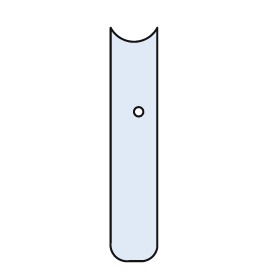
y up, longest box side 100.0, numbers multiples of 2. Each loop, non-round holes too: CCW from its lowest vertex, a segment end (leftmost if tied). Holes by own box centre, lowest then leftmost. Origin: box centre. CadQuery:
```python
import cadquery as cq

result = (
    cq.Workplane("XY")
    .moveTo(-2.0, -50.0)
    .lineTo(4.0, -50.0)
    .threePointArc((8.0, -48.0), (10.0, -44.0))
    .lineTo(10.0, 50.0)
    .threePointArc((0.0, 44.0), (-10.0, 50.0))
    .lineTo(-10.0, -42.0)
    .threePointArc((-8.0, -48.0), (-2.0, -50.0))
    .close()
    .moveTo(2.0, 14.0)
    .circle(2.0)
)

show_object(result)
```